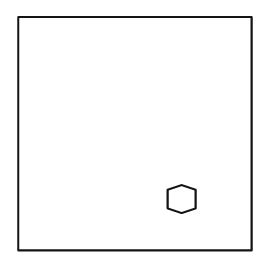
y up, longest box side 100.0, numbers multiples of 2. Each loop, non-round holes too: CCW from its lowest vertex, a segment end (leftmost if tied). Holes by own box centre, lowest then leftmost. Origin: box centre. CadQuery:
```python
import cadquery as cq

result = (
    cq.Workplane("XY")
    .moveTo(-50.0, -50.0)
    .lineTo(50.0, -50.0)
    .lineTo(50.0, 50.0)
    .lineTo(-50.0, 50.0)
    .close()
    .moveTo(20.0, -34.0)
    .lineTo(26.0, -32.0)
    .lineTo(26.0, -24.0)
    .lineTo(20.0, -22.0)
    .lineTo(14.0, -24.0)
    .lineTo(14.0, -32.0)
    .close()
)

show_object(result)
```